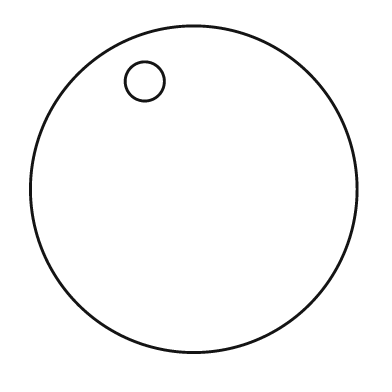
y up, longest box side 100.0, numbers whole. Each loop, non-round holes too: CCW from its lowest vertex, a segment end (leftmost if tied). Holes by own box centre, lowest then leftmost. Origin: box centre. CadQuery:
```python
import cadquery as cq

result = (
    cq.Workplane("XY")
    .moveTo(0.0, 0.0)
    .circle(50.0)
    .moveTo(-15.0, 33.0)
    .circle(6.0)
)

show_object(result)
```